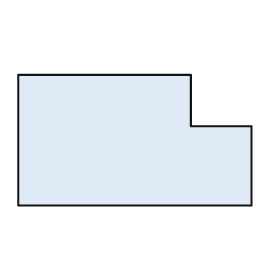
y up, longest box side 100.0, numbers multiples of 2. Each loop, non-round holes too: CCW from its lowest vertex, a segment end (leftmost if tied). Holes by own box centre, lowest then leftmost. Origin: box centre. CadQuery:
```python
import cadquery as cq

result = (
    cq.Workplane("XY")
    .moveTo(-50.0, -28.0)
    .lineTo(50.0, -28.0)
    .lineTo(50.0, 6.0)
    .lineTo(24.0, 6.0)
    .lineTo(24.0, 28.0)
    .lineTo(-50.0, 28.0)
    .close()
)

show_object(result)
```